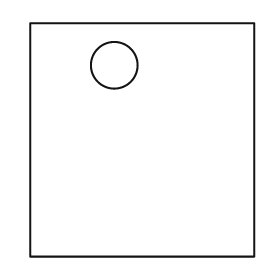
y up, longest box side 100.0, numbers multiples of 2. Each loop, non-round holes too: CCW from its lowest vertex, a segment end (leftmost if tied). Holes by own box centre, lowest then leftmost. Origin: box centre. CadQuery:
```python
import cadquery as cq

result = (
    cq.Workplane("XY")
    .moveTo(-48.0, -50.0)
    .lineTo(48.0, -50.0)
    .lineTo(48.0, 50.0)
    .lineTo(-48.0, 50.0)
    .close()
    .moveTo(-12.0, 32.0)
    .circle(10.0)
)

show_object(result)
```